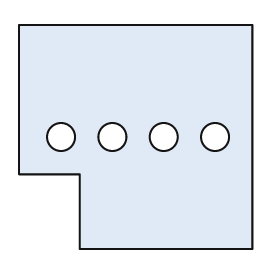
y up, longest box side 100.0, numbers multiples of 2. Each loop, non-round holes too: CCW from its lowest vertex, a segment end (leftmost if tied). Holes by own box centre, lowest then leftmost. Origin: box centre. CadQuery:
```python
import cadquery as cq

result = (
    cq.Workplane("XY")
    .moveTo(-24.0, -48.0)
    .lineTo(50.0, -48.0)
    .lineTo(50.0, 48.0)
    .lineTo(-50.0, 48.0)
    .lineTo(-50.0, -16.0)
    .lineTo(-24.0, -16.0)
    .close()
    .moveTo(-32.0, 0.0)
    .circle(6.0)
    .moveTo(-10.0, 0.0)
    .circle(6.0)
    .moveTo(12.0, 0.0)
    .circle(6.0)
    .moveTo(34.0, 0.0)
    .circle(6.0)
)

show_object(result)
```